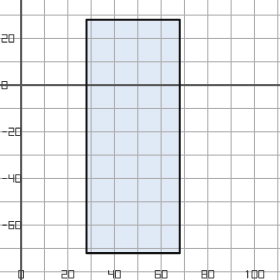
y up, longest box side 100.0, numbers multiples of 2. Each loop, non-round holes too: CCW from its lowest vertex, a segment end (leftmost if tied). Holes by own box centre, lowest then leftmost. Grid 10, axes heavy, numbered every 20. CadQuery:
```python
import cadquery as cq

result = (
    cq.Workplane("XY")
    .moveTo(28.0, -72.0)
    .lineTo(68.0, -72.0)
    .lineTo(68.0, 28.0)
    .lineTo(28.0, 28.0)
    .close()
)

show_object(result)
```